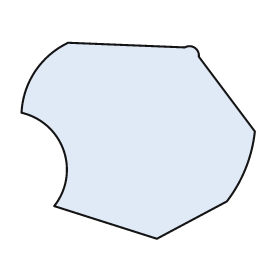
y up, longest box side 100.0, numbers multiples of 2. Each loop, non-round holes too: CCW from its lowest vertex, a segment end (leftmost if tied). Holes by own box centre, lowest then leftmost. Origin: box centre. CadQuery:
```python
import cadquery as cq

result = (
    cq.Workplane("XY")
    .moveTo(8.0, -42.0)
    .lineTo(38.0, -26.0)
    .threePointArc((46.0, -12.0), (50.0, 4.0))
    .lineTo(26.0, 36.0)
    .threePointArc((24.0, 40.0), (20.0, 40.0))
    .lineTo(-30.0, 42.0)
    .threePointArc((-44.0, 30.0), (-50.0, 12.0))
    .threePointArc((-32.0, -4.0), (-36.0, -28.0))
    .close()
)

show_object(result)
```